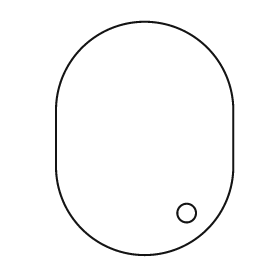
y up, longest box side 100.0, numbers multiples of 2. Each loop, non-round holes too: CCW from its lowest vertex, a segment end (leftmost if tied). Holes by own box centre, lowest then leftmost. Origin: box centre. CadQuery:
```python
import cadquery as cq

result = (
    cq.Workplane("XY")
    .moveTo(-38.0, -12.0)
    .threePointArc((0.0, -50.0), (38.0, -12.0))
    .lineTo(38.0, 12.0)
    .threePointArc((0.0, 50.0), (-38.0, 12.0))
    .close()
    .moveTo(18.0, -32.0)
    .circle(4.0)
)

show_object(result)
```